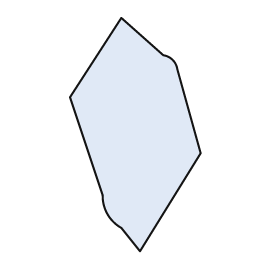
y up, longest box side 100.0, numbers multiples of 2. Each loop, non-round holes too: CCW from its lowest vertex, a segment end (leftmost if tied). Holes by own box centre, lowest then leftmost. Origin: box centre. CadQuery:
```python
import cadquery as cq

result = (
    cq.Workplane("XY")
    .moveTo(2.0, -50.0)
    .lineTo(28.0, -8.0)
    .lineTo(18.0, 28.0)
    .threePointArc((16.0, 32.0), (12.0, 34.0))
    .lineTo(-6.0, 50.0)
    .lineTo(-28.0, 16.0)
    .lineTo(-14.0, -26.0)
    .threePointArc((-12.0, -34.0), (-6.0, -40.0))
    .close()
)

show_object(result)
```